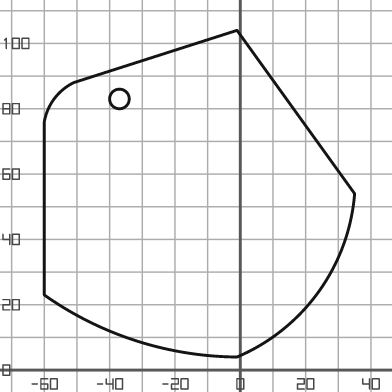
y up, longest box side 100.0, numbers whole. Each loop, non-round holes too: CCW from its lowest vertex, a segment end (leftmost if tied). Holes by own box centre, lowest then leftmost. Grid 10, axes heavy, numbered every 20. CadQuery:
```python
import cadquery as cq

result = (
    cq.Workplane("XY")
    .moveTo(-1.0, 4.0)
    .threePointArc((24.0, 24.0), (35.0, 54.0))
    .lineTo(-1.0, 104.0)
    .lineTo(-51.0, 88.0)
    .threePointArc((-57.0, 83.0), (-60.0, 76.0))
    .lineTo(-60.0, 23.0)
    .threePointArc((-32.0, 9.0), (-1.0, 4.0))
    .close()
    .moveTo(-37.0, 83.0)
    .circle(3.0)
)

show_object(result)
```